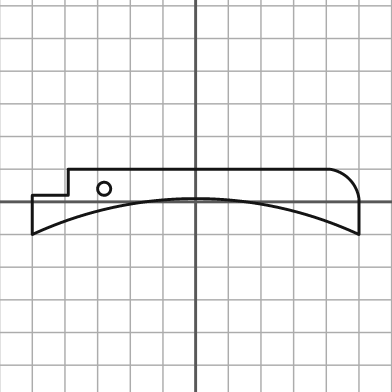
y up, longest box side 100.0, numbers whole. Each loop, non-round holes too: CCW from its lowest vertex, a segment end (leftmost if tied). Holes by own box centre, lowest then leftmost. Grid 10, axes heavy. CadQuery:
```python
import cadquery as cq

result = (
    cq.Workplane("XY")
    .moveTo(-50.0, -10.0)
    .threePointArc((0.0, 1.0), (50.0, -10.0))
    .lineTo(50.0, 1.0)
    .threePointArc((47.0, 7.0), (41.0, 10.0))
    .lineTo(-39.0, 10.0)
    .lineTo(-39.0, 2.0)
    .lineTo(-50.0, 2.0)
    .close()
    .moveTo(-28.0, 4.0)
    .circle(2.0)
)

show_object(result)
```